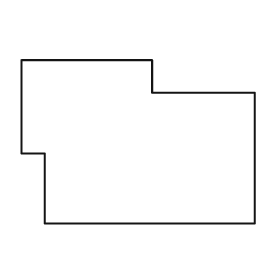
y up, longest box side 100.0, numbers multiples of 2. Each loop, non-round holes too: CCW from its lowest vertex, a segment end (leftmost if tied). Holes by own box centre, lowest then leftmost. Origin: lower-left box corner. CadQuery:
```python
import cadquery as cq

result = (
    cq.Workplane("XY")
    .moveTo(10.0, 0.0)
    .lineTo(100.0, 0.0)
    .lineTo(100.0, 56.0)
    .lineTo(56.0, 56.0)
    .lineTo(56.0, 70.0)
    .lineTo(0.0, 70.0)
    .lineTo(0.0, 30.0)
    .lineTo(10.0, 30.0)
    .close()
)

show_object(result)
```